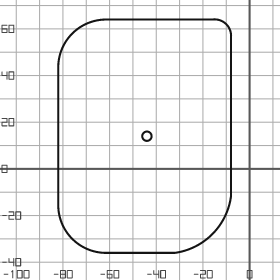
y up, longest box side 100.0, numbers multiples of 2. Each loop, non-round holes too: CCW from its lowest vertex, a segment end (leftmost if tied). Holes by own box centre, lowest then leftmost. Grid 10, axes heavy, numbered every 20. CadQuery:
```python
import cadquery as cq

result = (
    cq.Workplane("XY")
    .moveTo(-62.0, -36.0)
    .lineTo(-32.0, -36.0)
    .threePointArc((-16.0, -28.0), (-8.0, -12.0))
    .lineTo(-8.0, 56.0)
    .threePointArc((-10.0, 62.0), (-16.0, 64.0))
    .lineTo(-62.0, 64.0)
    .threePointArc((-76.0, 58.0), (-82.0, 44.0))
    .lineTo(-82.0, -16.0)
    .threePointArc((-76.0, -30.0), (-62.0, -36.0))
    .close()
    .moveTo(-44.0, 14.0)
    .circle(2.0)
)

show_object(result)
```